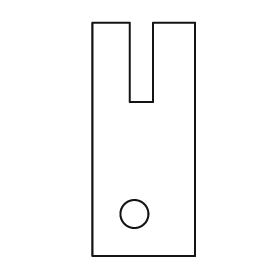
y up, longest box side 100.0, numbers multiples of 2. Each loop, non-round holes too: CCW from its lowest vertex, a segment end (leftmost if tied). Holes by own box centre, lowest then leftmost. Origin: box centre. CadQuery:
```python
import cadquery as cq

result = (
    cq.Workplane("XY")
    .moveTo(-22.0, -50.0)
    .lineTo(22.0, -50.0)
    .lineTo(22.0, 50.0)
    .lineTo(4.0, 50.0)
    .lineTo(4.0, 16.0)
    .lineTo(-6.0, 16.0)
    .lineTo(-6.0, 50.0)
    .lineTo(-22.0, 50.0)
    .close()
    .moveTo(-4.0, -32.0)
    .circle(6.0)
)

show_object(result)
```